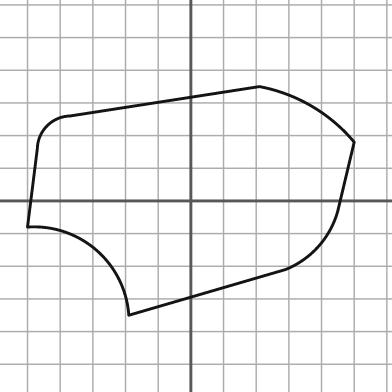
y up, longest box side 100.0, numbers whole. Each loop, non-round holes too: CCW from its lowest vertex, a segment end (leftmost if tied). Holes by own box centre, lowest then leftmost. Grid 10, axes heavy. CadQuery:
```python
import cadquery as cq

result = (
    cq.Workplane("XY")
    .moveTo(-19.0, -35.0)
    .lineTo(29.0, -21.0)
    .threePointArc((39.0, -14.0), (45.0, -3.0))
    .lineTo(50.0, 18.0)
    .threePointArc((37.0, 29.0), (21.0, 35.0))
    .lineTo(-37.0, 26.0)
    .threePointArc((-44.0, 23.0), (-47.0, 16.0))
    .lineTo(-50.0, -8.0)
    .threePointArc((-29.0, -15.0), (-19.0, -35.0))
    .close()
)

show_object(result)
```